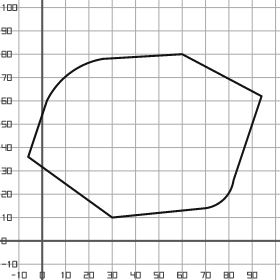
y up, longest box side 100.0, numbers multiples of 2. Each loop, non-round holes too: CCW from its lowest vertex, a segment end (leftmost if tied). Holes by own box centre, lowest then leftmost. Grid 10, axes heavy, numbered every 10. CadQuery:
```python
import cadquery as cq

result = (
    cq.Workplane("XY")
    .moveTo(30.0, 10.0)
    .lineTo(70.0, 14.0)
    .threePointArc((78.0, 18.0), (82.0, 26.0))
    .lineTo(94.0, 62.0)
    .lineTo(60.0, 80.0)
    .lineTo(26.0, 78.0)
    .threePointArc((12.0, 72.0), (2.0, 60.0))
    .lineTo(-6.0, 36.0)
    .close()
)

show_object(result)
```